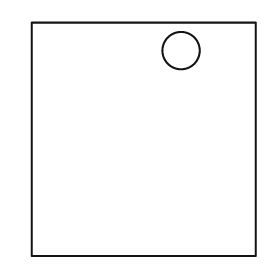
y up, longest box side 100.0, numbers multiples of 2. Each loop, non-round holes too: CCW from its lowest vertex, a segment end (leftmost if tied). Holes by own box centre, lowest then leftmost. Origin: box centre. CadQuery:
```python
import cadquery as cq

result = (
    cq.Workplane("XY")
    .moveTo(-48.0, -50.0)
    .lineTo(48.0, -50.0)
    .lineTo(48.0, 50.0)
    .lineTo(-48.0, 50.0)
    .close()
    .moveTo(16.0, 38.0)
    .circle(8.0)
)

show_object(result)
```